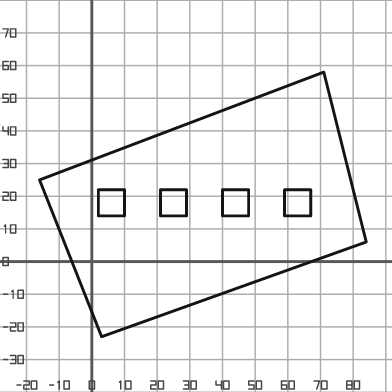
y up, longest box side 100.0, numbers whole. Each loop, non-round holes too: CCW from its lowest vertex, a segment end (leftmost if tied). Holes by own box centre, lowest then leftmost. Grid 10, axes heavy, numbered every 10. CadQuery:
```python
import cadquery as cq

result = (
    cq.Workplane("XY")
    .moveTo(3.0, -23.0)
    .lineTo(84.0, 6.0)
    .lineTo(71.0, 58.0)
    .lineTo(-16.0, 25.0)
    .close()
    .moveTo(2.0, 14.0)
    .lineTo(10.0, 14.0)
    .lineTo(10.0, 22.0)
    .lineTo(2.0, 22.0)
    .close()
    .moveTo(21.0, 14.0)
    .lineTo(29.0, 14.0)
    .lineTo(29.0, 22.0)
    .lineTo(21.0, 22.0)
    .close()
    .moveTo(40.0, 14.0)
    .lineTo(48.0, 14.0)
    .lineTo(48.0, 22.0)
    .lineTo(40.0, 22.0)
    .close()
    .moveTo(59.0, 14.0)
    .lineTo(67.0, 14.0)
    .lineTo(67.0, 22.0)
    .lineTo(59.0, 22.0)
    .close()
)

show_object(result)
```